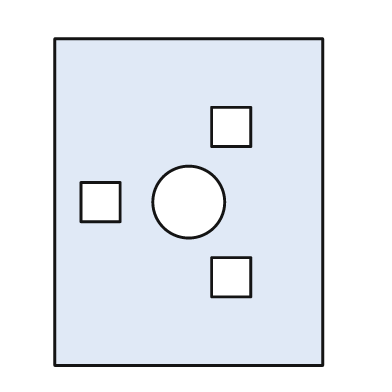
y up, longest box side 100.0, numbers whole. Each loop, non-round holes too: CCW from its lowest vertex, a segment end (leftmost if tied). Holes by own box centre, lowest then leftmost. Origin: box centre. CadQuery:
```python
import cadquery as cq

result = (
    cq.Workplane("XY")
    .moveTo(-41.0, -50.0)
    .lineTo(41.0, -50.0)
    .lineTo(41.0, 50.0)
    .lineTo(-41.0, 50.0)
    .close()
    .moveTo(7.0, -29.0)
    .lineTo(19.0, -29.0)
    .lineTo(19.0, -17.0)
    .lineTo(7.0, -17.0)
    .close()
    .moveTo(-33.0, -6.0)
    .lineTo(-21.0, -6.0)
    .lineTo(-21.0, 6.0)
    .lineTo(-33.0, 6.0)
    .close()
    .moveTo(0.0, 0.0)
    .circle(11.0)
    .moveTo(7.0, 17.0)
    .lineTo(19.0, 17.0)
    .lineTo(19.0, 29.0)
    .lineTo(7.0, 29.0)
    .close()
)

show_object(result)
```